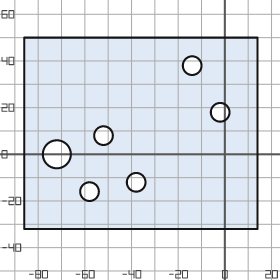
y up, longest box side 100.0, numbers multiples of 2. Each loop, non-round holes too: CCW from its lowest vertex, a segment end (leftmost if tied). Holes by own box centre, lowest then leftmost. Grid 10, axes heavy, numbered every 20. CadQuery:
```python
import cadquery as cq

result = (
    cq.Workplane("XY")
    .moveTo(-86.0, -32.0)
    .lineTo(14.0, -32.0)
    .lineTo(14.0, 50.0)
    .lineTo(-86.0, 50.0)
    .close()
    .moveTo(-58.0, -16.0)
    .circle(4.0)
    .moveTo(-38.0, -12.0)
    .circle(4.0)
    .moveTo(-72.0, 0.0)
    .circle(6.0)
    .moveTo(-52.0, 8.0)
    .circle(4.0)
    .moveTo(-2.0, 18.0)
    .circle(4.0)
    .moveTo(-14.0, 38.0)
    .circle(4.0)
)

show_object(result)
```